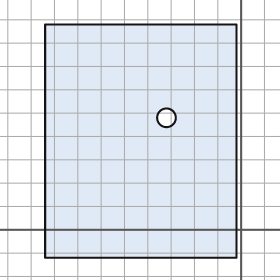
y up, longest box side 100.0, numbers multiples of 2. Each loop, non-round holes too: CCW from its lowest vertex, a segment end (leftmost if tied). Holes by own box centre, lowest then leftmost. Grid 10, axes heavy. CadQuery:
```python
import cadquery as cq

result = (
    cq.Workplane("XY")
    .moveTo(-84.0, -12.0)
    .lineTo(-2.0, -12.0)
    .lineTo(-2.0, 88.0)
    .lineTo(-84.0, 88.0)
    .close()
    .moveTo(-32.0, 48.0)
    .circle(4.0)
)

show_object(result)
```